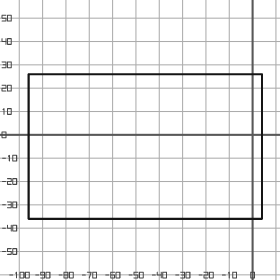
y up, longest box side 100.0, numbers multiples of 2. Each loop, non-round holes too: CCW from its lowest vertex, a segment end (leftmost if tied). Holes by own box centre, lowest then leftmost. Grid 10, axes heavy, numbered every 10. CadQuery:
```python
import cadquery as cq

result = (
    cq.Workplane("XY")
    .moveTo(-96.0, -36.0)
    .lineTo(4.0, -36.0)
    .lineTo(4.0, 26.0)
    .lineTo(-96.0, 26.0)
    .close()
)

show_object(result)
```